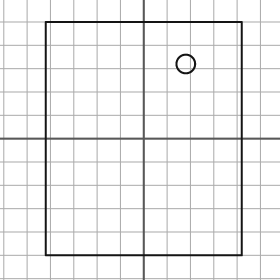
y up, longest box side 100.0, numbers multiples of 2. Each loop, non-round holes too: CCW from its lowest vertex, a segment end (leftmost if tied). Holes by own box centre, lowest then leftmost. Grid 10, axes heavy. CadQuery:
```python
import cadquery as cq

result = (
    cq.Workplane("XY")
    .moveTo(-42.0, -50.0)
    .lineTo(42.0, -50.0)
    .lineTo(42.0, 50.0)
    .lineTo(-42.0, 50.0)
    .close()
    .moveTo(18.0, 32.0)
    .circle(4.0)
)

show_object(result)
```